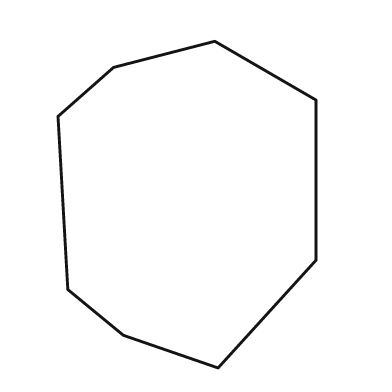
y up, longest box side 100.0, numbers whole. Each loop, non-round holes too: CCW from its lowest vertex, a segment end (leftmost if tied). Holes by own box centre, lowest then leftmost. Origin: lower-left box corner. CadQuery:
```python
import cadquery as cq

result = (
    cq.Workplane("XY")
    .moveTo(49.0, 0.0)
    .lineTo(79.0, 33.0)
    .lineTo(79.0, 82.0)
    .lineTo(48.0, 100.0)
    .lineTo(17.0, 92.0)
    .lineTo(0.0, 77.0)
    .lineTo(3.0, 24.0)
    .lineTo(20.0, 10.0)
    .close()
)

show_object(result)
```